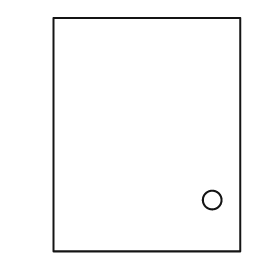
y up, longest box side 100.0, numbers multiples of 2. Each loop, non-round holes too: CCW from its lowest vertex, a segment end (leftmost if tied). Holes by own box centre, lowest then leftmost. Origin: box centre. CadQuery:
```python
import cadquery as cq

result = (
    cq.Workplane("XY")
    .moveTo(-40.0, -50.0)
    .lineTo(40.0, -50.0)
    .lineTo(40.0, 50.0)
    .lineTo(-40.0, 50.0)
    .close()
    .moveTo(28.0, -28.0)
    .circle(4.0)
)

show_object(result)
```